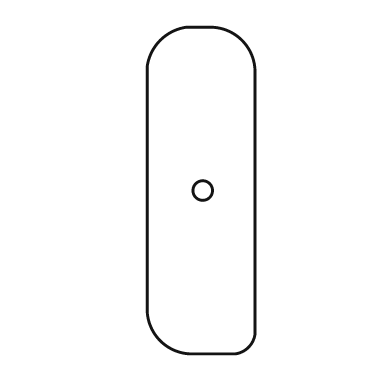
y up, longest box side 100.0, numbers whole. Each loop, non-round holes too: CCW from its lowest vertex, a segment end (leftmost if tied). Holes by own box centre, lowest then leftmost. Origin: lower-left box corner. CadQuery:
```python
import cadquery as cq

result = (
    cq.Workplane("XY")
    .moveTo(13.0, 0.0)
    .lineTo(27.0, 0.0)
    .threePointArc((31.0, 2.0), (33.0, 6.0))
    .lineTo(33.0, 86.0)
    .threePointArc((29.0, 96.0), (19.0, 100.0))
    .lineTo(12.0, 100.0)
    .threePointArc((4.0, 96.0), (0.0, 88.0))
    .lineTo(0.0, 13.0)
    .threePointArc((4.0, 4.0), (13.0, 0.0))
    .close()
    .moveTo(17.0, 50.0)
    .circle(3.0)
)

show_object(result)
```